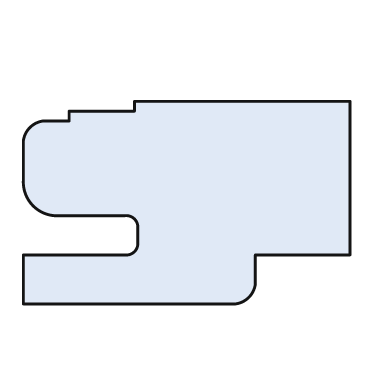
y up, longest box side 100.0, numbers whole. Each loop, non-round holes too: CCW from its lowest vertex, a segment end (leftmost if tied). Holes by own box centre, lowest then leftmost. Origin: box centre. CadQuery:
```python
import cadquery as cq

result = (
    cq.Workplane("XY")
    .moveTo(-50.0, -31.0)
    .lineTo(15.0, -31.0)
    .threePointArc((19.0, -29.0), (21.0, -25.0))
    .lineTo(21.0, -16.0)
    .lineTo(50.0, -16.0)
    .lineTo(50.0, 31.0)
    .lineTo(-16.0, 31.0)
    .lineTo(-16.0, 28.0)
    .lineTo(-36.0, 28.0)
    .lineTo(-36.0, 25.0)
    .lineTo(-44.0, 25.0)
    .threePointArc((-48.0, 23.0), (-50.0, 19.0))
    .lineTo(-50.0, 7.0)
    .threePointArc((-47.0, -1.0), (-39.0, -4.0))
    .lineTo(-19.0, -4.0)
    .threePointArc((-16.0, -5.0), (-15.0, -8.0))
    .lineTo(-15.0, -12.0)
    .threePointArc((-16.0, -15.0), (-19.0, -16.0))
    .lineTo(-50.0, -16.0)
    .close()
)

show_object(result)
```